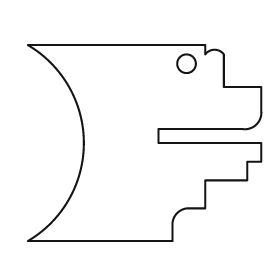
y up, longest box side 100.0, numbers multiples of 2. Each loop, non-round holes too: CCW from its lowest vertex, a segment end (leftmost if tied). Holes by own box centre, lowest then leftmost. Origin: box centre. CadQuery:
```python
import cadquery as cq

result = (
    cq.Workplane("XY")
    .moveTo(-50.0, -42.0)
    .lineTo(12.0, -42.0)
    .lineTo(12.0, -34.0)
    .threePointArc((14.0, -30.0), (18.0, -28.0))
    .lineTo(26.0, -28.0)
    .lineTo(26.0, -16.0)
    .lineTo(44.0, -16.0)
    .lineTo(44.0, -8.0)
    .lineTo(50.0, -8.0)
    .lineTo(50.0, 0.0)
    .lineTo(6.0, 0.0)
    .lineTo(6.0, 6.0)
    .lineTo(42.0, 6.0)
    .threePointArc((48.0, 8.0), (50.0, 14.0))
    .lineTo(50.0, 24.0)
    .lineTo(34.0, 24.0)
    .lineTo(34.0, 38.0)
    .threePointArc((30.0, 40.0), (26.0, 38.0))
    .lineTo(26.0, 42.0)
    .lineTo(-50.0, 42.0)
    .threePointArc((-26.0, 0.0), (-50.0, -42.0))
    .close()
    .moveTo(18.0, 34.0)
    .circle(4.0)
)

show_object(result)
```